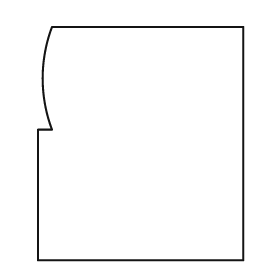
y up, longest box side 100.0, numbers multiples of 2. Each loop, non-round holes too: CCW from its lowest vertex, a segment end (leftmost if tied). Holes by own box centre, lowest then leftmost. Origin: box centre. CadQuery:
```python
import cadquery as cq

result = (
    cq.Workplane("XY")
    .moveTo(-44.0, -50.0)
    .lineTo(44.0, -50.0)
    .lineTo(44.0, 50.0)
    .lineTo(-38.0, 50.0)
    .threePointArc((-42.0, 28.0), (-38.0, 6.0))
    .lineTo(-44.0, 6.0)
    .close()
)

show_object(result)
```